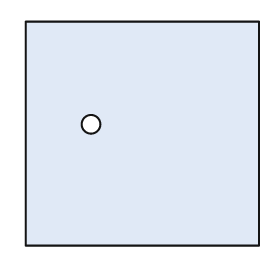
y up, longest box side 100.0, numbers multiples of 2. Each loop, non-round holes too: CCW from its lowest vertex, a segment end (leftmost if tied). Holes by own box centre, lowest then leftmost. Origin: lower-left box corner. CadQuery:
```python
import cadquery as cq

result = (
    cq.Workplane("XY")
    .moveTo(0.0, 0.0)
    .lineTo(100.0, 0.0)
    .lineTo(100.0, 96.0)
    .lineTo(0.0, 96.0)
    .close()
    .moveTo(28.0, 52.0)
    .circle(4.0)
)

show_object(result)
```